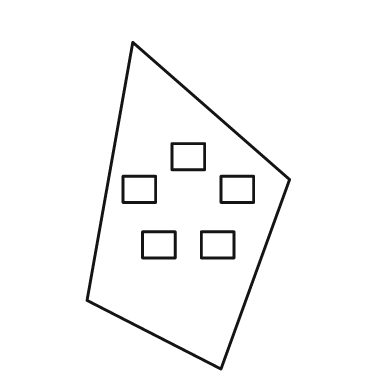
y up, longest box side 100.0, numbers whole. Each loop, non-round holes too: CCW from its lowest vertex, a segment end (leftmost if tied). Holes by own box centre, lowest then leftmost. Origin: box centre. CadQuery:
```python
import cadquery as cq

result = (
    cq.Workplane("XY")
    .moveTo(10.0, -50.0)
    .lineTo(31.0, 8.0)
    .lineTo(-17.0, 50.0)
    .lineTo(-31.0, -29.0)
    .close()
    .moveTo(-14.0, -16.0)
    .lineTo(-4.0, -16.0)
    .lineTo(-4.0, -8.0)
    .lineTo(-14.0, -8.0)
    .close()
    .moveTo(4.0, -16.0)
    .lineTo(14.0, -16.0)
    .lineTo(14.0, -8.0)
    .lineTo(4.0, -8.0)
    .close()
    .moveTo(-20.0, 1.0)
    .lineTo(-10.0, 1.0)
    .lineTo(-10.0, 9.0)
    .lineTo(-20.0, 9.0)
    .close()
    .moveTo(10.0, 1.0)
    .lineTo(20.0, 1.0)
    .lineTo(20.0, 9.0)
    .lineTo(10.0, 9.0)
    .close()
    .moveTo(-5.0, 11.0)
    .lineTo(5.0, 11.0)
    .lineTo(5.0, 19.0)
    .lineTo(-5.0, 19.0)
    .close()
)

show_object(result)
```